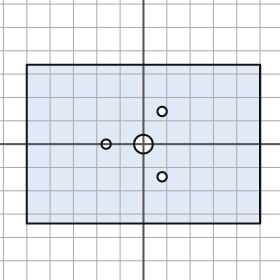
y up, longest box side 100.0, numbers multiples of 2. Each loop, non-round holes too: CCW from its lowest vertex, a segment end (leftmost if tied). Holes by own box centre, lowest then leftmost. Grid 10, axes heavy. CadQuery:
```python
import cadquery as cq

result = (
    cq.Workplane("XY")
    .moveTo(-50.0, -34.0)
    .lineTo(50.0, -34.0)
    .lineTo(50.0, 34.0)
    .lineTo(-50.0, 34.0)
    .close()
    .moveTo(8.0, -14.0)
    .circle(2.0)
    .moveTo(-16.0, 0.0)
    .circle(2.0)
    .moveTo(0.0, 0.0)
    .circle(4.0)
    .moveTo(8.0, 14.0)
    .circle(2.0)
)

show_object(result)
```